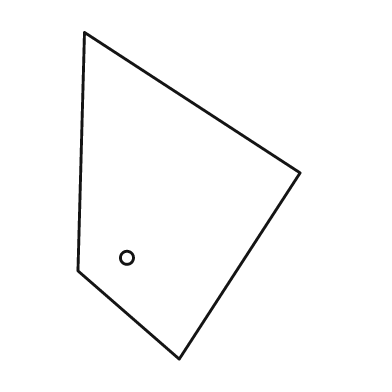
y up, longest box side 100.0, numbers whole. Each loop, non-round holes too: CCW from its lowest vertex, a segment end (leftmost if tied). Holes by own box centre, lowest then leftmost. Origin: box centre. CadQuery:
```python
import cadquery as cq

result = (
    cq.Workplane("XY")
    .moveTo(-3.0, -50.0)
    .lineTo(34.0, 7.0)
    .lineTo(-32.0, 50.0)
    .lineTo(-34.0, -23.0)
    .close()
    .moveTo(-19.0, -19.0)
    .circle(2.0)
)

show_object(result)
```